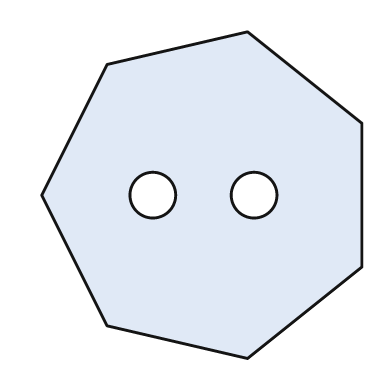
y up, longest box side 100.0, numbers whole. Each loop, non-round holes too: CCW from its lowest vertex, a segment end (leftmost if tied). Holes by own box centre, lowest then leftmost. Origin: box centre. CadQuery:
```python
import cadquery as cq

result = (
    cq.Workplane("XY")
    .moveTo(14.0, -50.0)
    .lineTo(49.0, -22.0)
    .lineTo(49.0, 22.0)
    .lineTo(14.0, 50.0)
    .lineTo(-29.0, 40.0)
    .lineTo(-49.0, 0.0)
    .lineTo(-29.0, -40.0)
    .close()
    .moveTo(-15.0, 0.0)
    .circle(7.0)
    .moveTo(16.0, 0.0)
    .circle(7.0)
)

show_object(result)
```